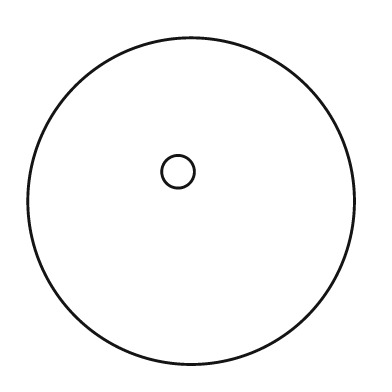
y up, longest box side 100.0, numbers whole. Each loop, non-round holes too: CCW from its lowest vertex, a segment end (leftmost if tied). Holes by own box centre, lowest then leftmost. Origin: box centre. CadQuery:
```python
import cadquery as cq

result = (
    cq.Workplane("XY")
    .moveTo(0.0, 0.0)
    .circle(50.0)
    .moveTo(-4.0, 9.0)
    .circle(5.0)
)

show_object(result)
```